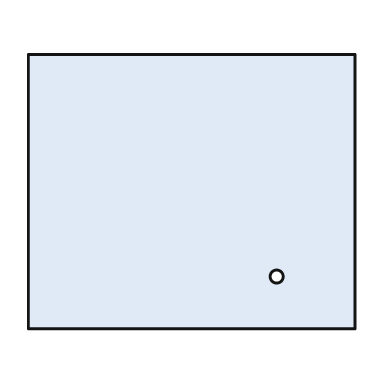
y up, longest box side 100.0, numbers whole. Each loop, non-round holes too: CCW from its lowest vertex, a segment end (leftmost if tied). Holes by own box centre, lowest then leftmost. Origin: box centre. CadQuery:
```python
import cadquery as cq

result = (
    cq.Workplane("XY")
    .moveTo(-50.0, -42.0)
    .lineTo(50.0, -42.0)
    .lineTo(50.0, 42.0)
    .lineTo(-50.0, 42.0)
    .close()
    .moveTo(26.0, -26.0)
    .circle(2.0)
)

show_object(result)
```